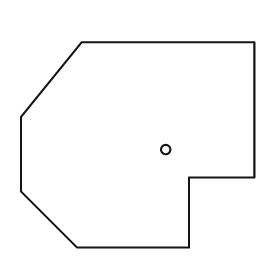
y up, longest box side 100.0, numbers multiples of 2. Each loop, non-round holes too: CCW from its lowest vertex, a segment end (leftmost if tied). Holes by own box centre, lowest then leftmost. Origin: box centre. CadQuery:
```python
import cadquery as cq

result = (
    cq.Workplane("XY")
    .moveTo(-26.0, -44.0)
    .lineTo(22.0, -44.0)
    .lineTo(22.0, -14.0)
    .lineTo(50.0, -14.0)
    .lineTo(50.0, 44.0)
    .lineTo(-24.0, 44.0)
    .lineTo(-50.0, 12.0)
    .lineTo(-50.0, -20.0)
    .close()
    .moveTo(12.0, -2.0)
    .circle(2.0)
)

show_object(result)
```